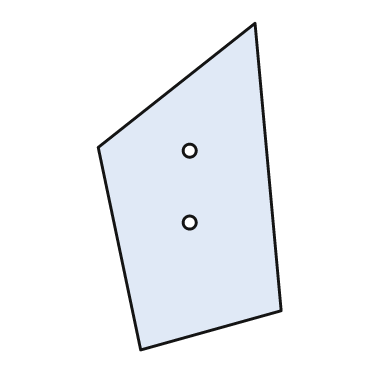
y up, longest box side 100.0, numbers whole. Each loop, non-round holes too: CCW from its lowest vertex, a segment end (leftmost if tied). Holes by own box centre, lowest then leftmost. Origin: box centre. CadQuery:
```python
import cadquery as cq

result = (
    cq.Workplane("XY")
    .moveTo(-15.0, -50.0)
    .lineTo(28.0, -38.0)
    .lineTo(20.0, 50.0)
    .lineTo(-28.0, 12.0)
    .close()
    .moveTo(0.0, -11.0)
    .circle(2.0)
    .moveTo(0.0, 11.0)
    .circle(2.0)
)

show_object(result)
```